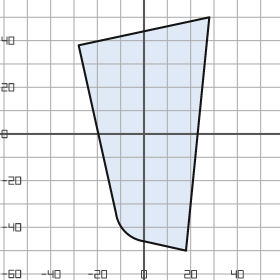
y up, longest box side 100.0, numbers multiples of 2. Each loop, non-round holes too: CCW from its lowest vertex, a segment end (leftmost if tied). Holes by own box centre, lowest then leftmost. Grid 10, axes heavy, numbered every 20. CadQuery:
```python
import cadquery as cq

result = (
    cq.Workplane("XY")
    .moveTo(18.0, -50.0)
    .lineTo(28.0, 50.0)
    .lineTo(-28.0, 38.0)
    .lineTo(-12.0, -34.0)
    .threePointArc((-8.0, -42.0), (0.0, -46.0))
    .close()
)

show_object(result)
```